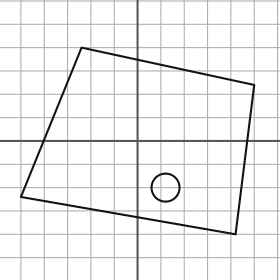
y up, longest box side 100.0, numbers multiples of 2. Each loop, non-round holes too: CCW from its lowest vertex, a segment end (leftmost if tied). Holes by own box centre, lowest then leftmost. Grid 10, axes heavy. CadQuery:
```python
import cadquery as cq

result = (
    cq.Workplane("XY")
    .moveTo(42.0, -40.0)
    .lineTo(50.0, 24.0)
    .lineTo(-24.0, 40.0)
    .lineTo(-50.0, -24.0)
    .close()
    .moveTo(12.0, -20.0)
    .circle(6.0)
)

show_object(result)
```